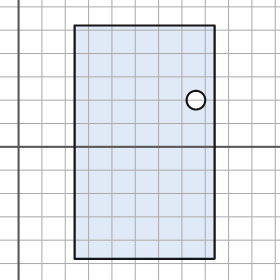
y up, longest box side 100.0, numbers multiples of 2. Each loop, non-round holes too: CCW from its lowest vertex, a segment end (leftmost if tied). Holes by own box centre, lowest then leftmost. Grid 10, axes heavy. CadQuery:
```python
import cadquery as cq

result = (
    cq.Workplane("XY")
    .moveTo(24.0, -48.0)
    .lineTo(84.0, -48.0)
    .lineTo(84.0, 52.0)
    .lineTo(24.0, 52.0)
    .close()
    .moveTo(76.0, 20.0)
    .circle(4.0)
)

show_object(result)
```